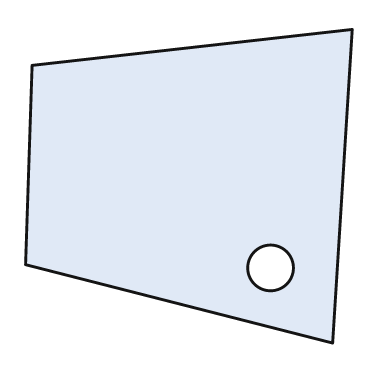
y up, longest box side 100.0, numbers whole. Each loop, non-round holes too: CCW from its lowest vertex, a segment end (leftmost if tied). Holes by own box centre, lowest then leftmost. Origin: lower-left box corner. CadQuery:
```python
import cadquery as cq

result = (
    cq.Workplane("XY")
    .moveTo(94.0, 0.0)
    .lineTo(100.0, 96.0)
    .lineTo(2.0, 85.0)
    .lineTo(0.0, 24.0)
    .close()
    .moveTo(75.0, 23.0)
    .circle(7.0)
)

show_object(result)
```